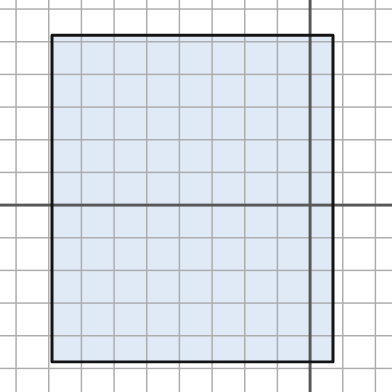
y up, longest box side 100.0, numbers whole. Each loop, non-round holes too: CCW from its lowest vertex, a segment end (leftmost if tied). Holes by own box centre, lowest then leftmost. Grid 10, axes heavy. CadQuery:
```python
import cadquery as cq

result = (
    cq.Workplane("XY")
    .moveTo(-79.0, -48.0)
    .lineTo(7.0, -48.0)
    .lineTo(7.0, 52.0)
    .lineTo(-79.0, 52.0)
    .close()
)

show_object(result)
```